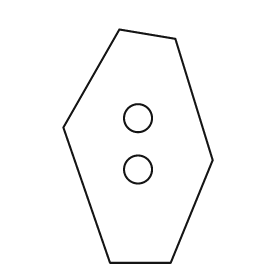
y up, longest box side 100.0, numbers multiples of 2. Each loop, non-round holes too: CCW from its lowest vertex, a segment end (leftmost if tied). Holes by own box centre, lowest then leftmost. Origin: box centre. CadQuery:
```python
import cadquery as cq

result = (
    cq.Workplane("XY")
    .moveTo(-12.0, -50.0)
    .lineTo(14.0, -50.0)
    .lineTo(32.0, -6.0)
    .lineTo(16.0, 46.0)
    .lineTo(-8.0, 50.0)
    .lineTo(-32.0, 8.0)
    .close()
    .moveTo(0.0, -10.0)
    .circle(6.0)
    .moveTo(0.0, 12.0)
    .circle(6.0)
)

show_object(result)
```